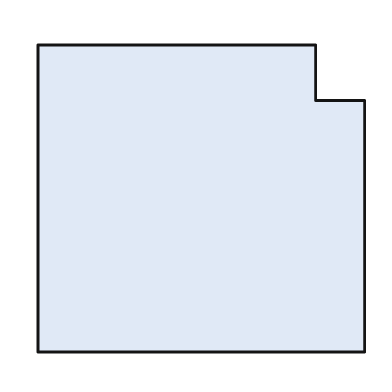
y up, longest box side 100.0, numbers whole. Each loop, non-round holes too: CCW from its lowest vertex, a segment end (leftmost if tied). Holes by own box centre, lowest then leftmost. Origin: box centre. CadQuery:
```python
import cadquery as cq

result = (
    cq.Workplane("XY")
    .moveTo(-50.0, -47.0)
    .lineTo(50.0, -47.0)
    .lineTo(50.0, 30.0)
    .lineTo(35.0, 30.0)
    .lineTo(35.0, 47.0)
    .lineTo(-50.0, 47.0)
    .close()
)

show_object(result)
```